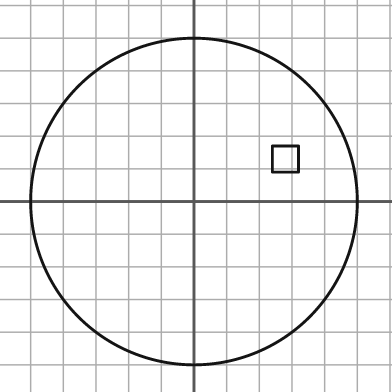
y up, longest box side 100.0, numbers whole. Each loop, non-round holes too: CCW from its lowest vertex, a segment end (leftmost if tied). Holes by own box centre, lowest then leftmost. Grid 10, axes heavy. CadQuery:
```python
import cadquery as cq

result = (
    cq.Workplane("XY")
    .moveTo(0.0, 0.0)
    .circle(50.0)
    .moveTo(24.0, 9.0)
    .lineTo(32.0, 9.0)
    .lineTo(32.0, 17.0)
    .lineTo(24.0, 17.0)
    .close()
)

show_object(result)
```